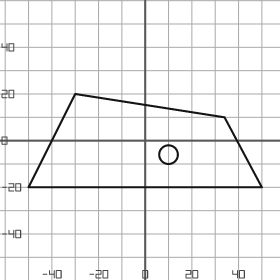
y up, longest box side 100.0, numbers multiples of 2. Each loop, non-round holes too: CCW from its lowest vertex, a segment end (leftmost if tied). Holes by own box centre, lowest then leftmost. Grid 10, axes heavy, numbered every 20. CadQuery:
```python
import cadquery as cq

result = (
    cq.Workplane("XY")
    .moveTo(-50.0, -20.0)
    .lineTo(50.0, -20.0)
    .lineTo(34.0, 10.0)
    .lineTo(-30.0, 20.0)
    .close()
    .moveTo(10.0, -6.0)
    .circle(4.0)
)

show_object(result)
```